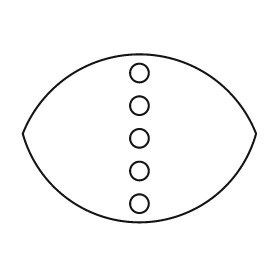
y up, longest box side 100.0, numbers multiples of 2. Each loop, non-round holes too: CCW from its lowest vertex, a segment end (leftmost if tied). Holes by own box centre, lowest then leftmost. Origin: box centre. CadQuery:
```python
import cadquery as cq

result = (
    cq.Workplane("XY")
    .moveTo(-50.0, 2.0)
    .threePointArc((0.0, -36.0), (50.0, 2.0))
    .threePointArc((0.0, 36.0), (-50.0, 2.0))
    .close()
    .moveTo(0.0, -28.0)
    .circle(4.0)
    .moveTo(0.0, -14.0)
    .circle(4.0)
    .moveTo(0.0, 0.0)
    .circle(4.0)
    .moveTo(0.0, 14.0)
    .circle(4.0)
    .moveTo(0.0, 28.0)
    .circle(4.0)
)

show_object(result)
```